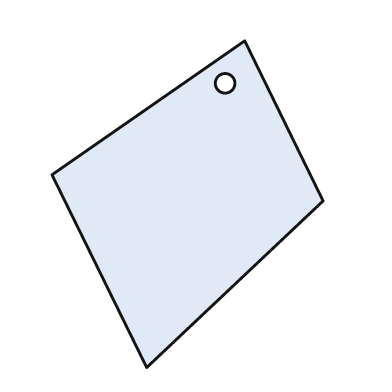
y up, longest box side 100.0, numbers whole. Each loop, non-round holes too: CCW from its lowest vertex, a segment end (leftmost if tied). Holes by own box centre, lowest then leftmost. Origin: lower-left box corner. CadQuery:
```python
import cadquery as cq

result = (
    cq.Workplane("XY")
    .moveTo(29.0, 0.0)
    .lineTo(83.0, 51.0)
    .lineTo(59.0, 100.0)
    .lineTo(0.0, 59.0)
    .close()
    .moveTo(53.0, 87.0)
    .circle(3.0)
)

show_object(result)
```